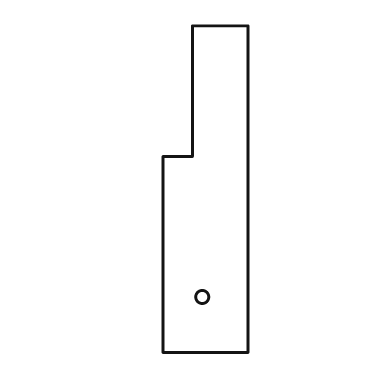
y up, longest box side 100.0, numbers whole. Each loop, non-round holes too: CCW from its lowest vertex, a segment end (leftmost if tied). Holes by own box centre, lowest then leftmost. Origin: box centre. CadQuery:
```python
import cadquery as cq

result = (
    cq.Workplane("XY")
    .moveTo(-13.0, -50.0)
    .lineTo(13.0, -50.0)
    .lineTo(13.0, 50.0)
    .lineTo(-4.0, 50.0)
    .lineTo(-4.0, 10.0)
    .lineTo(-13.0, 10.0)
    .close()
    .moveTo(-1.0, -33.0)
    .circle(2.0)
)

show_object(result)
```